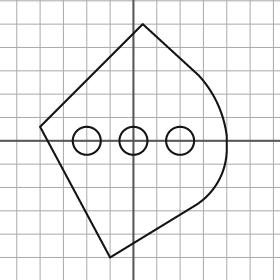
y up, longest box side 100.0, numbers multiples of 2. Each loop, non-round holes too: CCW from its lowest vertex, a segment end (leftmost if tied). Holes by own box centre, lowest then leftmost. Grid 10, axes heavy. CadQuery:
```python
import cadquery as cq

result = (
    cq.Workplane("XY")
    .moveTo(-10.0, -50.0)
    .lineTo(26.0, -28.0)
    .threePointArc((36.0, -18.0), (40.0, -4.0))
    .lineTo(40.0, 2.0)
    .threePointArc((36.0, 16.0), (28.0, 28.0))
    .lineTo(4.0, 50.0)
    .lineTo(-40.0, 6.0)
    .close()
    .moveTo(-20.0, 0.0)
    .circle(6.0)
    .moveTo(0.0, 0.0)
    .circle(6.0)
    .moveTo(20.0, 0.0)
    .circle(6.0)
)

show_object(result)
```